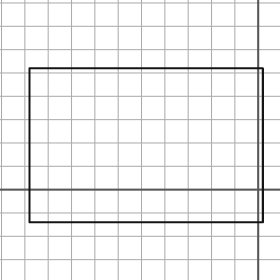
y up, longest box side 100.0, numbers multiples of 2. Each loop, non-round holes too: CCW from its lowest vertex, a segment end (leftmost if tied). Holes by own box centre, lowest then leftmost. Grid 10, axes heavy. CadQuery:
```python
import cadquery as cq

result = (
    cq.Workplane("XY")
    .moveTo(-98.0, -14.0)
    .lineTo(2.0, -14.0)
    .lineTo(2.0, 52.0)
    .lineTo(-98.0, 52.0)
    .close()
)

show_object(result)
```